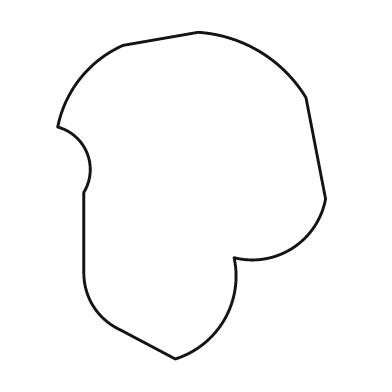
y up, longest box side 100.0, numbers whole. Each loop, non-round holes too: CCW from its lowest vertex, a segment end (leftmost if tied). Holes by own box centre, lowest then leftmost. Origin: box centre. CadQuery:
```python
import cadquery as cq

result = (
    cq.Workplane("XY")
    .moveTo(-5.0, -50.0)
    .threePointArc((10.0, -38.0), (13.0, -19.0))
    .threePointArc((31.0, -16.0), (41.0, -1.0))
    .lineTo(35.0, 30.0)
    .threePointArc((21.0, 44.0), (2.0, 50.0))
    .lineTo(-21.0, 46.0)
    .threePointArc((-34.0, 36.0), (-41.0, 21.0))
    .threePointArc((-32.0, 13.0), (-33.0, 1.0))
    .lineTo(-33.0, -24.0)
    .threePointArc((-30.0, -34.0), (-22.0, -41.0))
    .close()
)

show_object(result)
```